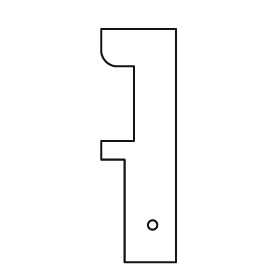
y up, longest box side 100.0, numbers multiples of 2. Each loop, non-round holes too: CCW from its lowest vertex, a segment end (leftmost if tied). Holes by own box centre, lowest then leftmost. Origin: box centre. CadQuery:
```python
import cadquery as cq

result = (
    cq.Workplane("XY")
    .moveTo(-6.0, -50.0)
    .lineTo(16.0, -50.0)
    .lineTo(16.0, 50.0)
    .lineTo(-16.0, 50.0)
    .lineTo(-16.0, 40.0)
    .threePointArc((-14.0, 36.0), (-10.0, 34.0))
    .lineTo(-2.0, 34.0)
    .lineTo(-2.0, 2.0)
    .lineTo(-16.0, 2.0)
    .lineTo(-16.0, -6.0)
    .lineTo(-6.0, -6.0)
    .close()
    .moveTo(6.0, -34.0)
    .circle(2.0)
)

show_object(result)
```